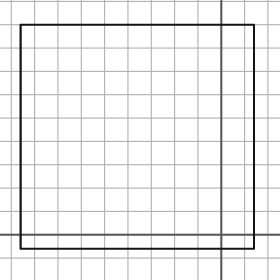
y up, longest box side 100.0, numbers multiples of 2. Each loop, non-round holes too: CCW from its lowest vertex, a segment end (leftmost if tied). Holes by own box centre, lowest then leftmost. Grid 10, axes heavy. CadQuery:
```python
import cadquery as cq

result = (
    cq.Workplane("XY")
    .moveTo(-86.0, -6.0)
    .lineTo(14.0, -6.0)
    .lineTo(14.0, 90.0)
    .lineTo(-86.0, 90.0)
    .close()
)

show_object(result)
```